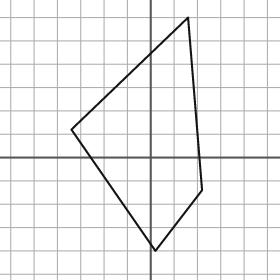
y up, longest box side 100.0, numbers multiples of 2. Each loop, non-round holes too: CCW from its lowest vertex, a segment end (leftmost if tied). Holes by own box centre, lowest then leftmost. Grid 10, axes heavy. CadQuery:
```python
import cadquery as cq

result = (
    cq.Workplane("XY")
    .moveTo(2.0, -40.0)
    .lineTo(22.0, -14.0)
    .lineTo(16.0, 60.0)
    .lineTo(-34.0, 12.0)
    .close()
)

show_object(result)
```